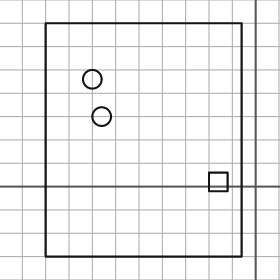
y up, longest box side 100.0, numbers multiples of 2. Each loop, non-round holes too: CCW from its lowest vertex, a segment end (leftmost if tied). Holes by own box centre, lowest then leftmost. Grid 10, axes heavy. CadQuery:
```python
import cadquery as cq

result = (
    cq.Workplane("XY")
    .moveTo(-90.0, -30.0)
    .lineTo(-6.0, -30.0)
    .lineTo(-6.0, 70.0)
    .lineTo(-90.0, 70.0)
    .close()
    .moveTo(-20.0, -2.0)
    .lineTo(-12.0, -2.0)
    .lineTo(-12.0, 6.0)
    .lineTo(-20.0, 6.0)
    .close()
    .moveTo(-66.0, 30.0)
    .circle(4.0)
    .moveTo(-70.0, 46.0)
    .circle(4.0)
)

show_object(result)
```